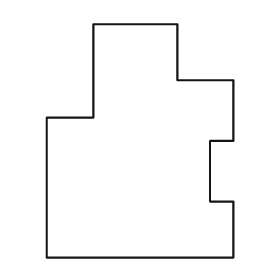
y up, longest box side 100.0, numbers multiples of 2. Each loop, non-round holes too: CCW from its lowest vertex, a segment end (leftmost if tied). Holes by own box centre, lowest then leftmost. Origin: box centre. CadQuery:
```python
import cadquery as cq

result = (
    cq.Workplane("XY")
    .moveTo(-40.0, -50.0)
    .lineTo(40.0, -50.0)
    .lineTo(40.0, -26.0)
    .lineTo(30.0, -26.0)
    .lineTo(30.0, 0.0)
    .lineTo(40.0, 0.0)
    .lineTo(40.0, 26.0)
    .lineTo(16.0, 26.0)
    .lineTo(16.0, 50.0)
    .lineTo(-20.0, 50.0)
    .lineTo(-20.0, 10.0)
    .lineTo(-40.0, 10.0)
    .close()
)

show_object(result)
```